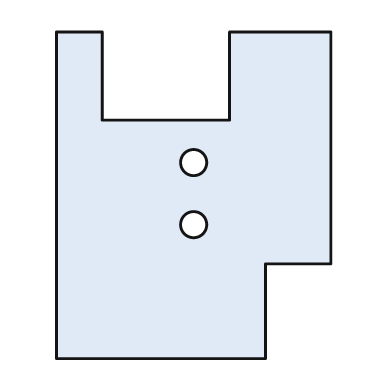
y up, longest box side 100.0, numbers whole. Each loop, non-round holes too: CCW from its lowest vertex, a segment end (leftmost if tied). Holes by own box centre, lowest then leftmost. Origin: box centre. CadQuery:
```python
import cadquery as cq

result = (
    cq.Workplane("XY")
    .moveTo(-42.0, -50.0)
    .lineTo(22.0, -50.0)
    .lineTo(22.0, -21.0)
    .lineTo(42.0, -21.0)
    .lineTo(42.0, 50.0)
    .lineTo(11.0, 50.0)
    .lineTo(11.0, 23.0)
    .lineTo(-28.0, 23.0)
    .lineTo(-28.0, 50.0)
    .lineTo(-42.0, 50.0)
    .close()
    .moveTo(0.0, -9.0)
    .circle(4.0)
    .moveTo(0.0, 10.0)
    .circle(4.0)
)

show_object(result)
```